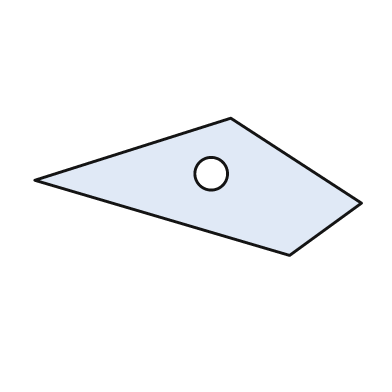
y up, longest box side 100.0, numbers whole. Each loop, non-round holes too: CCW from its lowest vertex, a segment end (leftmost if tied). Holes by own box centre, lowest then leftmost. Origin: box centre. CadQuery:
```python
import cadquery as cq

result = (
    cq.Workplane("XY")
    .moveTo(28.0, -21.0)
    .lineTo(50.0, -5.0)
    .lineTo(10.0, 21.0)
    .lineTo(-50.0, 2.0)
    .close()
    .moveTo(4.0, 4.0)
    .circle(5.0)
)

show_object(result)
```